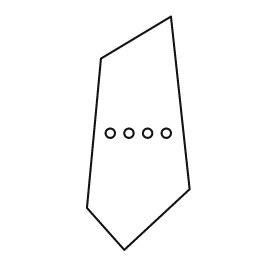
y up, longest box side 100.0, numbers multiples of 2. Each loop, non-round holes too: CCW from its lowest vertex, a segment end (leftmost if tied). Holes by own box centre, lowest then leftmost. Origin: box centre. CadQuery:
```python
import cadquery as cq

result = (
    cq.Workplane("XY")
    .moveTo(-6.0, -50.0)
    .lineTo(22.0, -24.0)
    .lineTo(14.0, 50.0)
    .lineTo(-16.0, 32.0)
    .lineTo(-22.0, -32.0)
    .close()
    .moveTo(-12.0, 0.0)
    .circle(2.0)
    .moveTo(-4.0, 0.0)
    .circle(2.0)
    .moveTo(4.0, 0.0)
    .circle(2.0)
    .moveTo(12.0, 0.0)
    .circle(2.0)
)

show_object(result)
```